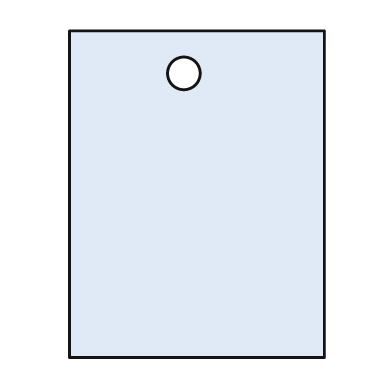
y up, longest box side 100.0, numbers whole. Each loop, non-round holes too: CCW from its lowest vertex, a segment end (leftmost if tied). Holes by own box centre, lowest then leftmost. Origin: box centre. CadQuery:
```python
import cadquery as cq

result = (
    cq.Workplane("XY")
    .moveTo(-39.0, -50.0)
    .lineTo(39.0, -50.0)
    .lineTo(39.0, 50.0)
    .lineTo(-39.0, 50.0)
    .close()
    .moveTo(-4.0, 37.0)
    .circle(5.0)
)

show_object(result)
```